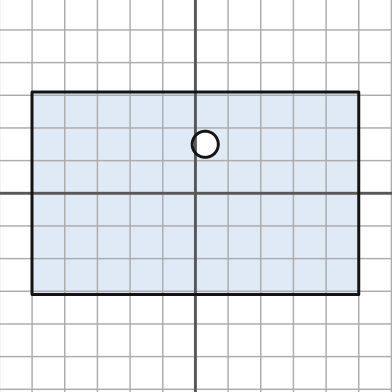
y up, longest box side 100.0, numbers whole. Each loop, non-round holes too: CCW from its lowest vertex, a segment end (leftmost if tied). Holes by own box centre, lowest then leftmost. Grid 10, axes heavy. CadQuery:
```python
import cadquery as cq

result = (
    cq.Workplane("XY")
    .moveTo(-50.0, -31.0)
    .lineTo(50.0, -31.0)
    .lineTo(50.0, 31.0)
    .lineTo(-50.0, 31.0)
    .close()
    .moveTo(3.0, 15.0)
    .circle(4.0)
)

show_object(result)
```